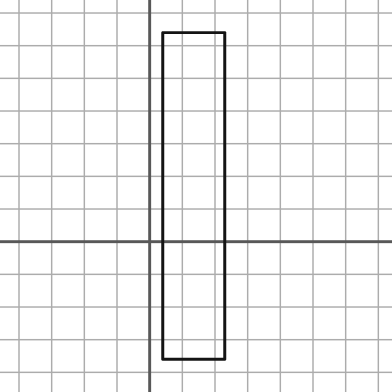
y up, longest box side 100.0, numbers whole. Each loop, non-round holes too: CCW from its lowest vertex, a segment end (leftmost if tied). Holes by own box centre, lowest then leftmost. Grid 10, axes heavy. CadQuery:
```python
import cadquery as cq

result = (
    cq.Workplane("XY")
    .moveTo(4.0, -36.0)
    .lineTo(23.0, -36.0)
    .lineTo(23.0, 64.0)
    .lineTo(4.0, 64.0)
    .close()
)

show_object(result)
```